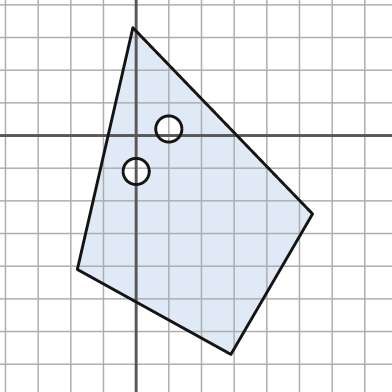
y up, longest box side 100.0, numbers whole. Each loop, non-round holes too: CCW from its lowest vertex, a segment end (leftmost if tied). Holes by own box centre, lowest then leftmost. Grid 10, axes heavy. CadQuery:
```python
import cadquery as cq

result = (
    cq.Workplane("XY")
    .moveTo(29.0, -67.0)
    .lineTo(54.0, -24.0)
    .lineTo(-1.0, 33.0)
    .lineTo(-18.0, -41.0)
    .close()
    .moveTo(0.0, -11.0)
    .circle(4.0)
    .moveTo(10.0, 2.0)
    .circle(4.0)
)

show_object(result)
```